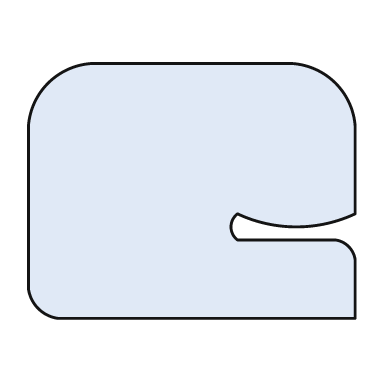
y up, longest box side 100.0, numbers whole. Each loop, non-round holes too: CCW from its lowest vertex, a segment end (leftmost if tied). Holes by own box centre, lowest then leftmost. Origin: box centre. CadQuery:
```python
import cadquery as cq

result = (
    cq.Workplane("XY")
    .moveTo(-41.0, -39.0)
    .lineTo(50.0, -39.0)
    .lineTo(50.0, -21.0)
    .threePointArc((48.0, -17.0), (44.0, -15.0))
    .lineTo(14.0, -15.0)
    .threePointArc((12.0, -11.0), (14.0, -7.0))
    .threePointArc((32.0, -11.0), (50.0, -7.0))
    .lineTo(50.0, 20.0)
    .threePointArc((44.0, 33.0), (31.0, 39.0))
    .lineTo(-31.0, 39.0)
    .threePointArc((-44.0, 33.0), (-50.0, 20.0))
    .lineTo(-50.0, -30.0)
    .threePointArc((-47.0, -36.0), (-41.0, -39.0))
    .close()
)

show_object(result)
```